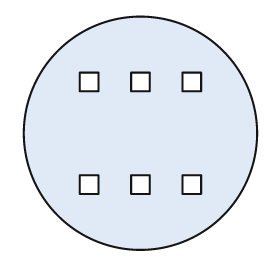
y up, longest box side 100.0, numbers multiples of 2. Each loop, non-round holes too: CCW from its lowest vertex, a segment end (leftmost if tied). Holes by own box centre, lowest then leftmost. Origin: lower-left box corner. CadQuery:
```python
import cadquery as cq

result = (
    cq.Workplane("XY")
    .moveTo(50.0, 50.0)
    .circle(50.0)
    .moveTo(24.0, 24.0)
    .lineTo(32.0, 24.0)
    .lineTo(32.0, 32.0)
    .lineTo(24.0, 32.0)
    .close()
    .moveTo(46.0, 24.0)
    .lineTo(54.0, 24.0)
    .lineTo(54.0, 32.0)
    .lineTo(46.0, 32.0)
    .close()
    .moveTo(68.0, 24.0)
    .lineTo(76.0, 24.0)
    .lineTo(76.0, 32.0)
    .lineTo(68.0, 32.0)
    .close()
    .moveTo(24.0, 68.0)
    .lineTo(32.0, 68.0)
    .lineTo(32.0, 76.0)
    .lineTo(24.0, 76.0)
    .close()
    .moveTo(46.0, 68.0)
    .lineTo(54.0, 68.0)
    .lineTo(54.0, 76.0)
    .lineTo(46.0, 76.0)
    .close()
    .moveTo(68.0, 68.0)
    .lineTo(76.0, 68.0)
    .lineTo(76.0, 76.0)
    .lineTo(68.0, 76.0)
    .close()
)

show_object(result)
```